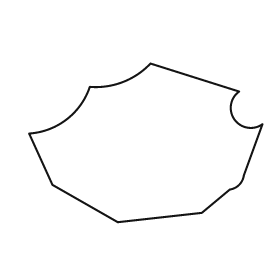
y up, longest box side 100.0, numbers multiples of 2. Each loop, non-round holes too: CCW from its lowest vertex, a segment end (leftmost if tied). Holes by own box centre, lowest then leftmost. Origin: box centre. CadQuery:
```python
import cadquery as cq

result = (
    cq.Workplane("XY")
    .moveTo(-12.0, -34.0)
    .lineTo(24.0, -30.0)
    .lineTo(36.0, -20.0)
    .threePointArc((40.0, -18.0), (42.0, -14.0))
    .lineTo(50.0, 8.0)
    .threePointArc((38.0, 10.0), (40.0, 22.0))
    .lineTo(2.0, 34.0)
    .threePointArc((-10.0, 26.0), (-24.0, 24.0))
    .threePointArc((-34.0, 10.0), (-50.0, 4.0))
    .lineTo(-40.0, -18.0)
    .close()
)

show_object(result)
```